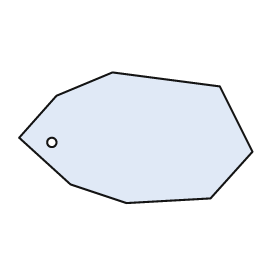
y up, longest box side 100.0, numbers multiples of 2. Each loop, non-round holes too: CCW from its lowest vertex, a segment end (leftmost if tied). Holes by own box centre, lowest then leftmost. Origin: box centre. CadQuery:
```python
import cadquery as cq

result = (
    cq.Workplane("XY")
    .moveTo(-4.0, -28.0)
    .lineTo(32.0, -26.0)
    .lineTo(50.0, -6.0)
    .lineTo(36.0, 22.0)
    .lineTo(-10.0, 28.0)
    .lineTo(-34.0, 18.0)
    .lineTo(-50.0, 0.0)
    .lineTo(-28.0, -20.0)
    .close()
    .moveTo(-36.0, -2.0)
    .circle(2.0)
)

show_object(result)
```